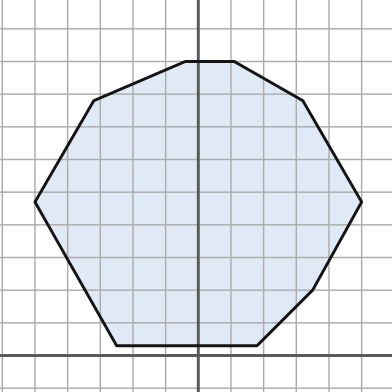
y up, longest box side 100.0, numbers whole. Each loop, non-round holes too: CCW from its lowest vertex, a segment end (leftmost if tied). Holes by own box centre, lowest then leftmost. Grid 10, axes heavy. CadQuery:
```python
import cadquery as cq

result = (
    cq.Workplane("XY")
    .moveTo(-25.0, 3.0)
    .lineTo(18.0, 3.0)
    .lineTo(35.0, 20.0)
    .lineTo(50.0, 47.0)
    .lineTo(32.0, 78.0)
    .lineTo(11.0, 90.0)
    .lineTo(-4.0, 90.0)
    .lineTo(-32.0, 78.0)
    .lineTo(-50.0, 47.0)
    .close()
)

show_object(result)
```